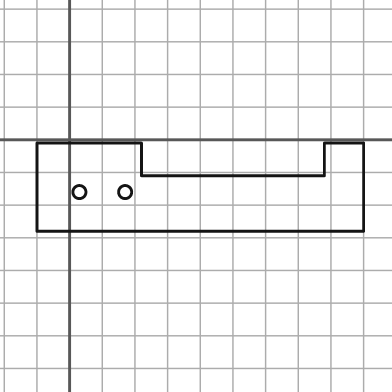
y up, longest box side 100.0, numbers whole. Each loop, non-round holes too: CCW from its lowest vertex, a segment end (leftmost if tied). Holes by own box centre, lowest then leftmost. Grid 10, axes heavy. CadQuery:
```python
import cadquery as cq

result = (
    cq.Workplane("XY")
    .moveTo(-10.0, -28.0)
    .lineTo(90.0, -28.0)
    .lineTo(90.0, -1.0)
    .lineTo(78.0, -1.0)
    .lineTo(78.0, -11.0)
    .lineTo(22.0, -11.0)
    .lineTo(22.0, -1.0)
    .lineTo(-10.0, -1.0)
    .close()
    .moveTo(3.0, -16.0)
    .circle(2.0)
    .moveTo(17.0, -16.0)
    .circle(2.0)
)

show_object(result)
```